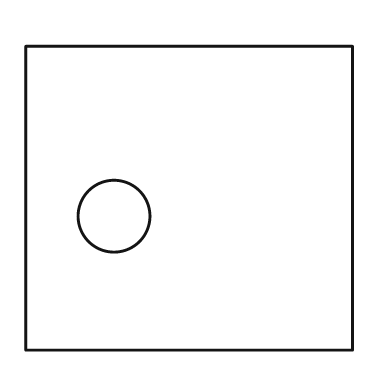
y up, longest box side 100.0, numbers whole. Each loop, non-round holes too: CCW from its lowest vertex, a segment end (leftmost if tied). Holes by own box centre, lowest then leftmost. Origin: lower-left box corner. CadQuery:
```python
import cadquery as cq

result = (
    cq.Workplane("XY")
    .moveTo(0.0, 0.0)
    .lineTo(100.0, 0.0)
    .lineTo(100.0, 93.0)
    .lineTo(0.0, 93.0)
    .close()
    .moveTo(27.0, 41.0)
    .circle(11.0)
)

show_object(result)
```